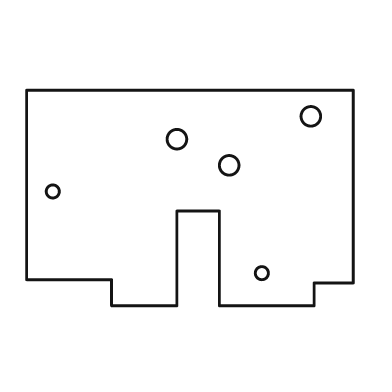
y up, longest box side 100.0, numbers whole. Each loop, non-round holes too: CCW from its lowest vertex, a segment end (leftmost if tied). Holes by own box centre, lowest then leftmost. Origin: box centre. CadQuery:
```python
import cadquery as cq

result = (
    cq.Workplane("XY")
    .moveTo(-24.0, -33.0)
    .lineTo(-4.0, -33.0)
    .lineTo(-4.0, -4.0)
    .lineTo(9.0, -4.0)
    .lineTo(9.0, -33.0)
    .lineTo(38.0, -33.0)
    .lineTo(38.0, -26.0)
    .lineTo(50.0, -26.0)
    .lineTo(50.0, 33.0)
    .lineTo(-50.0, 33.0)
    .lineTo(-50.0, -25.0)
    .lineTo(-24.0, -25.0)
    .close()
    .moveTo(22.0, -23.0)
    .circle(2.0)
    .moveTo(-42.0, 2.0)
    .circle(2.0)
    .moveTo(12.0, 10.0)
    .circle(3.0)
    .moveTo(-4.0, 18.0)
    .circle(3.0)
    .moveTo(37.0, 25.0)
    .circle(3.0)
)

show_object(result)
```